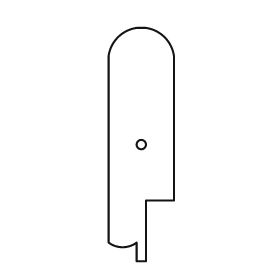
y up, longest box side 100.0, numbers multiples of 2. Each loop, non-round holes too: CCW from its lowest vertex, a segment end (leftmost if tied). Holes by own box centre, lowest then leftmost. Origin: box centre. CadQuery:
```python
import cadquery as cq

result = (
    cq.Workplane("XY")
    .moveTo(-2.0, -50.0)
    .lineTo(2.0, -50.0)
    .lineTo(2.0, -24.0)
    .lineTo(14.0, -24.0)
    .lineTo(14.0, 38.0)
    .threePointArc((10.0, 46.0), (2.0, 50.0))
    .lineTo(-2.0, 50.0)
    .threePointArc((-10.0, 46.0), (-14.0, 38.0))
    .lineTo(-14.0, -42.0)
    .threePointArc((-8.0, -44.0), (-2.0, -42.0))
    .close()
    .moveTo(0.0, 0.0)
    .circle(2.0)
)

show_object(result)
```